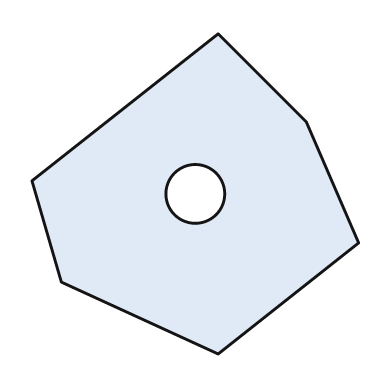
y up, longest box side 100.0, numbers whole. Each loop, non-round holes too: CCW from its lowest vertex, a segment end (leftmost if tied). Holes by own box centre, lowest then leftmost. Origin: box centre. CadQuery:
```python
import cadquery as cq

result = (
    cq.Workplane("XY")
    .moveTo(7.0, -49.0)
    .lineTo(50.0, -15.0)
    .lineTo(34.0, 22.0)
    .lineTo(7.0, 49.0)
    .lineTo(-50.0, 4.0)
    .lineTo(-41.0, -27.0)
    .close()
    .moveTo(0.0, 0.0)
    .circle(9.0)
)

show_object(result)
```